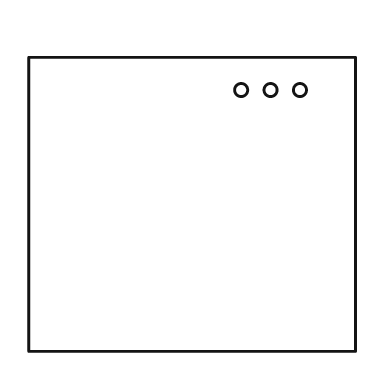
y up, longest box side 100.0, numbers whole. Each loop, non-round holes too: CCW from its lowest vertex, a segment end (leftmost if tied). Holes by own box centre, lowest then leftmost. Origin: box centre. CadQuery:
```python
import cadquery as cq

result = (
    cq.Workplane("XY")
    .moveTo(-50.0, -45.0)
    .lineTo(50.0, -45.0)
    .lineTo(50.0, 45.0)
    .lineTo(-50.0, 45.0)
    .close()
    .moveTo(15.0, 35.0)
    .circle(2.0)
    .moveTo(24.0, 35.0)
    .circle(2.0)
    .moveTo(33.0, 35.0)
    .circle(2.0)
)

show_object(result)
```